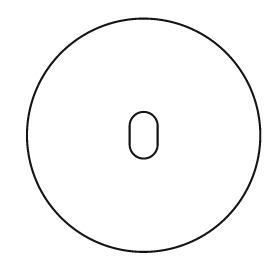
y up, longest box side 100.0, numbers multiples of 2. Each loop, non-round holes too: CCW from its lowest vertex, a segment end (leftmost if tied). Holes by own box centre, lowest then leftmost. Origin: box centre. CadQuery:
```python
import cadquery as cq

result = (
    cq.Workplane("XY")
    .moveTo(0.0, 0.0)
    .circle(50.0)
    .moveTo(-6.0, -4.0)
    .threePointArc((0.0, -10.0), (6.0, -4.0))
    .lineTo(6.0, 4.0)
    .threePointArc((0.0, 10.0), (-6.0, 4.0))
    .close()
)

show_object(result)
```